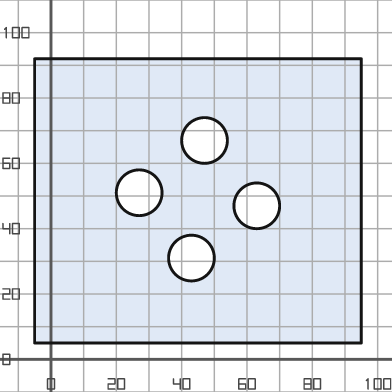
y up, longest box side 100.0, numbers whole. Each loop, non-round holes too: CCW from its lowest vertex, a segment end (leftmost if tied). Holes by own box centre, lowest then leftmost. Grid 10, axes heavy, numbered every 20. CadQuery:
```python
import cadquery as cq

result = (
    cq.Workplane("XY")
    .moveTo(-5.0, 5.0)
    .lineTo(95.0, 5.0)
    .lineTo(95.0, 92.0)
    .lineTo(-5.0, 92.0)
    .close()
    .moveTo(43.0, 31.0)
    .circle(7.0)
    .moveTo(63.0, 47.0)
    .circle(7.0)
    .moveTo(27.0, 51.0)
    .circle(7.0)
    .moveTo(47.0, 67.0)
    .circle(7.0)
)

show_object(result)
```